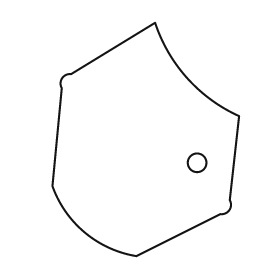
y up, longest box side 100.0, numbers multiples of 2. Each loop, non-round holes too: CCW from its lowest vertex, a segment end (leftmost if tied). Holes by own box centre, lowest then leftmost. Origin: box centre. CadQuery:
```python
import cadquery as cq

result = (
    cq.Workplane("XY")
    .moveTo(-4.0, -50.0)
    .lineTo(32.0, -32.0)
    .threePointArc((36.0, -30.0), (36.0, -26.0))
    .lineTo(40.0, 10.0)
    .threePointArc((18.0, 26.0), (4.0, 50.0))
    .lineTo(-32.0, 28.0)
    .threePointArc((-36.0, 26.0), (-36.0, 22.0))
    .lineTo(-40.0, -20.0)
    .threePointArc((-26.0, -40.0), (-4.0, -50.0))
    .close()
    .moveTo(22.0, -10.0)
    .circle(4.0)
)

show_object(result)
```